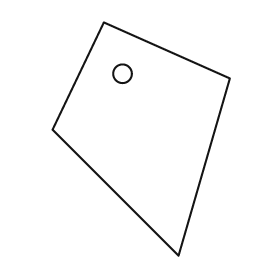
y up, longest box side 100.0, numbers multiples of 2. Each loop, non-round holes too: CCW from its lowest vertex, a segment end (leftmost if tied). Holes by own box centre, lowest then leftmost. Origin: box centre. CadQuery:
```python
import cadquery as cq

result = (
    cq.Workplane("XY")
    .moveTo(16.0, -50.0)
    .lineTo(38.0, 26.0)
    .lineTo(-16.0, 50.0)
    .lineTo(-38.0, 4.0)
    .close()
    .moveTo(-8.0, 28.0)
    .circle(4.0)
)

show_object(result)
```